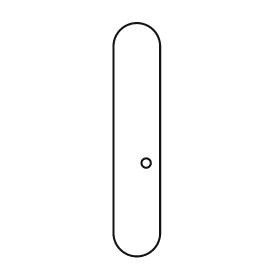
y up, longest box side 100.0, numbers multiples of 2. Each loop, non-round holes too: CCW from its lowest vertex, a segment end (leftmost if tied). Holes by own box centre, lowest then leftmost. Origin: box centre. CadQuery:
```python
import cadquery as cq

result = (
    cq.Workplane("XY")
    .moveTo(-10.0, -40.0)
    .threePointArc((0.0, -50.0), (10.0, -40.0))
    .lineTo(10.0, 40.0)
    .threePointArc((0.0, 50.0), (-10.0, 40.0))
    .close()
    .moveTo(4.0, -10.0)
    .circle(2.0)
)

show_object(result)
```